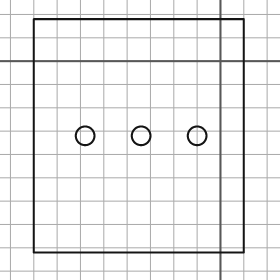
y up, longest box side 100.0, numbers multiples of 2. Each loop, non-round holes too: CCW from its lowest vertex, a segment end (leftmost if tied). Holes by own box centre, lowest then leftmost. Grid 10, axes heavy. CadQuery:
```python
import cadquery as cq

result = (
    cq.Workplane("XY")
    .moveTo(-80.0, -82.0)
    .lineTo(10.0, -82.0)
    .lineTo(10.0, 18.0)
    .lineTo(-80.0, 18.0)
    .close()
    .moveTo(-58.0, -32.0)
    .circle(4.0)
    .moveTo(-34.0, -32.0)
    .circle(4.0)
    .moveTo(-10.0, -32.0)
    .circle(4.0)
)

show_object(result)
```